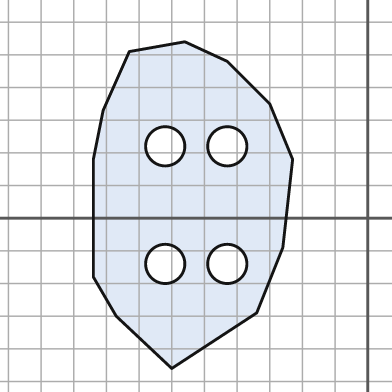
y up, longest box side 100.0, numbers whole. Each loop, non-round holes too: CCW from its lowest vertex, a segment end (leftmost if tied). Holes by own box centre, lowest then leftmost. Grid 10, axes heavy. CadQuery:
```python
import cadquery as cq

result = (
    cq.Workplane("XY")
    .moveTo(-60.0, -46.0)
    .lineTo(-34.0, -29.0)
    .lineTo(-26.0, -9.0)
    .lineTo(-23.0, 18.0)
    .lineTo(-30.0, 35.0)
    .lineTo(-43.0, 48.0)
    .lineTo(-56.0, 54.0)
    .lineTo(-73.0, 51.0)
    .lineTo(-81.0, 33.0)
    .lineTo(-84.0, 18.0)
    .lineTo(-84.0, -18.0)
    .lineTo(-77.0, -30.0)
    .close()
    .moveTo(-62.0, -14.0)
    .circle(6.0)
    .moveTo(-43.0, -14.0)
    .circle(6.0)
    .moveTo(-62.0, 22.0)
    .circle(6.0)
    .moveTo(-43.0, 22.0)
    .circle(6.0)
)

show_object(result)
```